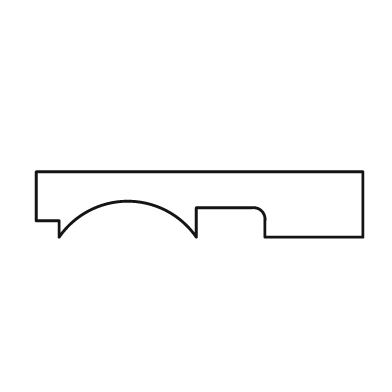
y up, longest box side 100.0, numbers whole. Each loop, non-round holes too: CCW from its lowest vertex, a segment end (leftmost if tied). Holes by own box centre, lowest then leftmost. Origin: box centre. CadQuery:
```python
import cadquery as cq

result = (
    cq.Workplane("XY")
    .moveTo(-43.0, -10.0)
    .threePointArc((-22.0, 1.0), (-1.0, -10.0))
    .lineTo(-1.0, -1.0)
    .lineTo(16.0, -1.0)
    .threePointArc((19.0, -2.0), (20.0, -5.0))
    .lineTo(20.0, -10.0)
    .lineTo(50.0, -10.0)
    .lineTo(50.0, 10.0)
    .lineTo(-50.0, 10.0)
    .lineTo(-50.0, -5.0)
    .lineTo(-43.0, -5.0)
    .close()
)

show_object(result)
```